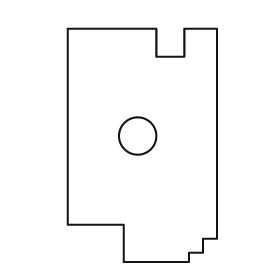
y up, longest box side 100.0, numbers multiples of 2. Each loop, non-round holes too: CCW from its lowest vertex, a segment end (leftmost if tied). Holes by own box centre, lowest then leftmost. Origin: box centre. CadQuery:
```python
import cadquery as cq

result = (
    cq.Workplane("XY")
    .moveTo(-8.0, -50.0)
    .lineTo(20.0, -50.0)
    .lineTo(20.0, -46.0)
    .lineTo(26.0, -46.0)
    .lineTo(26.0, -40.0)
    .lineTo(32.0, -40.0)
    .lineTo(32.0, 50.0)
    .lineTo(18.0, 50.0)
    .lineTo(18.0, 38.0)
    .lineTo(6.0, 38.0)
    .lineTo(6.0, 50.0)
    .lineTo(-32.0, 50.0)
    .lineTo(-32.0, -34.0)
    .lineTo(-8.0, -34.0)
    .close()
    .moveTo(-2.0, 4.0)
    .circle(8.0)
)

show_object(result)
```